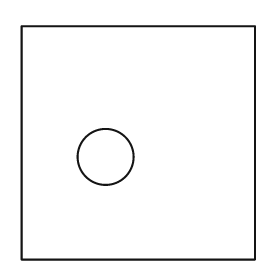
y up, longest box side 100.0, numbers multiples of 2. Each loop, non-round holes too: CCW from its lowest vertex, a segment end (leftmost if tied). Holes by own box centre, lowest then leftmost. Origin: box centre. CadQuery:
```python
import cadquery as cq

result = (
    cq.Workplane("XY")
    .moveTo(-50.0, -50.0)
    .lineTo(50.0, -50.0)
    .lineTo(50.0, 50.0)
    .lineTo(-50.0, 50.0)
    .close()
    .moveTo(-14.0, -6.0)
    .circle(12.0)
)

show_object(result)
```